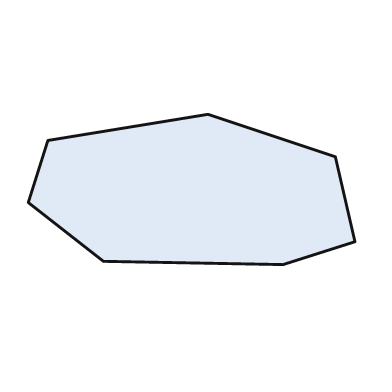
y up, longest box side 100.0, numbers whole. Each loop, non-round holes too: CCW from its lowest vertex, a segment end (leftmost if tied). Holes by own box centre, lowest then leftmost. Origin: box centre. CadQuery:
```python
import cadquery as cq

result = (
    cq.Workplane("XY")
    .moveTo(28.0, -23.0)
    .lineTo(50.0, -16.0)
    .lineTo(44.0, 10.0)
    .lineTo(5.0, 23.0)
    .lineTo(-44.0, 15.0)
    .lineTo(-50.0, -4.0)
    .lineTo(-27.0, -22.0)
    .close()
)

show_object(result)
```